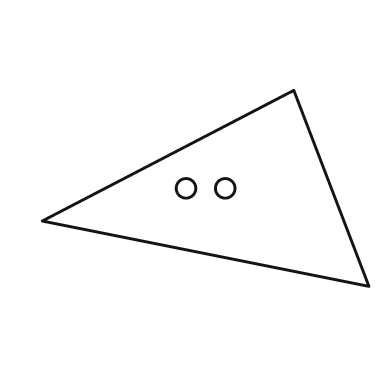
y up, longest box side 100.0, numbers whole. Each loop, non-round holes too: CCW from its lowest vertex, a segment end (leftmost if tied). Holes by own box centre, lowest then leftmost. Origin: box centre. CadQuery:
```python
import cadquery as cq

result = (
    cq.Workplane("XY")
    .moveTo(50.0, -30.0)
    .lineTo(27.0, 30.0)
    .lineTo(-50.0, -10.0)
    .close()
    .moveTo(-6.0, 0.0)
    .circle(3.0)
    .moveTo(6.0, 0.0)
    .circle(3.0)
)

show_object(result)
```